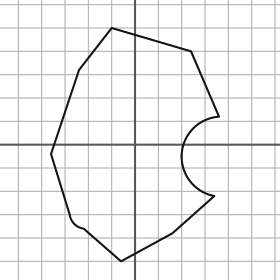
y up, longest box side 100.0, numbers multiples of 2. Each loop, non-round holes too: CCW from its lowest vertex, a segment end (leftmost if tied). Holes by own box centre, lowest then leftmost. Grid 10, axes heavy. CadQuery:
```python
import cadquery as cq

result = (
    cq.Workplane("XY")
    .moveTo(-6.0, -50.0)
    .lineTo(16.0, -38.0)
    .lineTo(34.0, -22.0)
    .threePointArc((20.0, -4.0), (36.0, 12.0))
    .lineTo(24.0, 40.0)
    .lineTo(-10.0, 50.0)
    .lineTo(-24.0, 32.0)
    .lineTo(-36.0, -4.0)
    .lineTo(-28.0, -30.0)
    .threePointArc((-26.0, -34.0), (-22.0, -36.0))
    .close()
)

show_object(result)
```